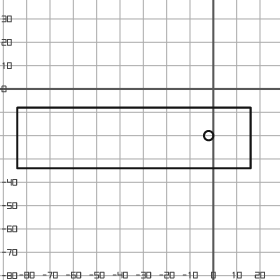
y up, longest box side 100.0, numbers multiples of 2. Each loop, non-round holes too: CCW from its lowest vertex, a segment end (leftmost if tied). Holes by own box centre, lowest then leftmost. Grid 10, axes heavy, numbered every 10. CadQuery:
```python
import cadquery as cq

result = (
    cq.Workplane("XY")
    .moveTo(-84.0, -34.0)
    .lineTo(16.0, -34.0)
    .lineTo(16.0, -8.0)
    .lineTo(-84.0, -8.0)
    .close()
    .moveTo(-2.0, -20.0)
    .circle(2.0)
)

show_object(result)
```